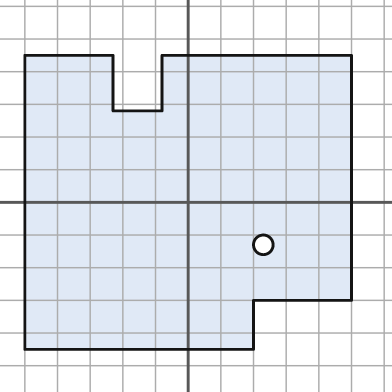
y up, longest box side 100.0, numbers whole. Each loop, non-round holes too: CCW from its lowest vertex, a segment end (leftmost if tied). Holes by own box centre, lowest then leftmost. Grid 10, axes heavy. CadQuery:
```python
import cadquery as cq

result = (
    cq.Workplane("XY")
    .moveTo(-50.0, -45.0)
    .lineTo(20.0, -45.0)
    .lineTo(20.0, -30.0)
    .lineTo(50.0, -30.0)
    .lineTo(50.0, 45.0)
    .lineTo(-8.0, 45.0)
    .lineTo(-8.0, 28.0)
    .lineTo(-23.0, 28.0)
    .lineTo(-23.0, 45.0)
    .lineTo(-50.0, 45.0)
    .close()
    .moveTo(23.0, -13.0)
    .circle(3.0)
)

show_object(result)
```